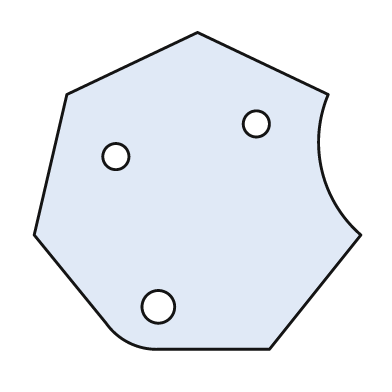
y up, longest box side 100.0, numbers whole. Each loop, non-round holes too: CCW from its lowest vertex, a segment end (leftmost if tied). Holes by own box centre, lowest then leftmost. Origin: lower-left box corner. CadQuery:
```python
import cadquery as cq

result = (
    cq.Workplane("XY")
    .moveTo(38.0, 0.0)
    .lineTo(72.0, 0.0)
    .lineTo(100.0, 35.0)
    .threePointArc((88.0, 55.0), (90.0, 78.0))
    .lineTo(50.0, 97.0)
    .lineTo(10.0, 78.0)
    .lineTo(0.0, 35.0)
    .lineTo(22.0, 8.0)
    .threePointArc((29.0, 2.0), (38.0, 0.0))
    .close()
    .moveTo(38.0, 13.0)
    .circle(5.0)
    .moveTo(25.0, 59.0)
    .circle(4.0)
    .moveTo(68.0, 69.0)
    .circle(4.0)
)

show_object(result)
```